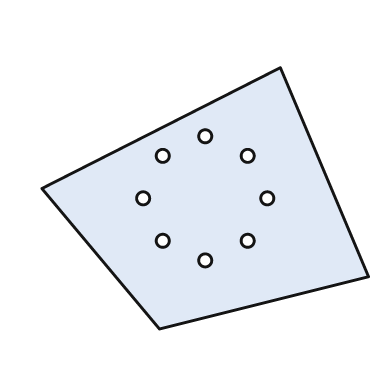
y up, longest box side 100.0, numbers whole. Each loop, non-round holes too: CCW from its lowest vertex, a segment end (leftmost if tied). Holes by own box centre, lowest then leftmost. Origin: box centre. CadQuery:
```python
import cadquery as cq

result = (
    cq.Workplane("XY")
    .moveTo(-14.0, -40.0)
    .lineTo(50.0, -24.0)
    .lineTo(23.0, 40.0)
    .lineTo(-50.0, 3.0)
    .close()
    .moveTo(0.0, -19.0)
    .circle(2.0)
    .moveTo(-13.0, -13.0)
    .circle(2.0)
    .moveTo(13.0, -13.0)
    .circle(2.0)
    .moveTo(-19.0, 0.0)
    .circle(2.0)
    .moveTo(19.0, 0.0)
    .circle(2.0)
    .moveTo(-13.0, 13.0)
    .circle(2.0)
    .moveTo(13.0, 13.0)
    .circle(2.0)
    .moveTo(0.0, 19.0)
    .circle(2.0)
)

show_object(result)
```